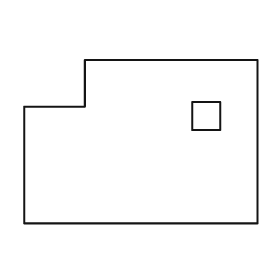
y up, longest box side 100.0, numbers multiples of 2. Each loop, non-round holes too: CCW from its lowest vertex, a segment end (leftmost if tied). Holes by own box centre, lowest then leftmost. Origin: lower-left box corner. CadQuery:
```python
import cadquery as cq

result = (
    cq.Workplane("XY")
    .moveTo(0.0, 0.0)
    .lineTo(100.0, 0.0)
    .lineTo(100.0, 70.0)
    .lineTo(26.0, 70.0)
    .lineTo(26.0, 50.0)
    .lineTo(0.0, 50.0)
    .close()
    .moveTo(72.0, 40.0)
    .lineTo(84.0, 40.0)
    .lineTo(84.0, 52.0)
    .lineTo(72.0, 52.0)
    .close()
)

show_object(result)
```